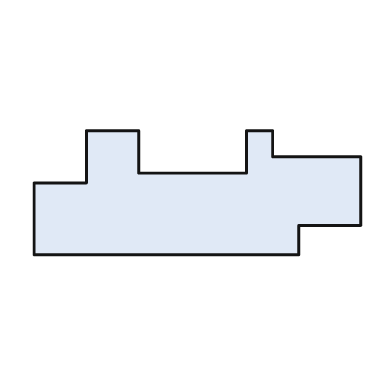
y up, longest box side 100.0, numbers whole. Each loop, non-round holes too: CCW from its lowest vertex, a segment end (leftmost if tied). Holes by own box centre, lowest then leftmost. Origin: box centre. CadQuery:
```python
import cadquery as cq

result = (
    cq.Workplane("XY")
    .moveTo(-50.0, -19.0)
    .lineTo(31.0, -19.0)
    .lineTo(31.0, -10.0)
    .lineTo(50.0, -10.0)
    .lineTo(50.0, 11.0)
    .lineTo(23.0, 11.0)
    .lineTo(23.0, 19.0)
    .lineTo(15.0, 19.0)
    .lineTo(15.0, 6.0)
    .lineTo(-18.0, 6.0)
    .lineTo(-18.0, 19.0)
    .lineTo(-34.0, 19.0)
    .lineTo(-34.0, 3.0)
    .lineTo(-50.0, 3.0)
    .close()
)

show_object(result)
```